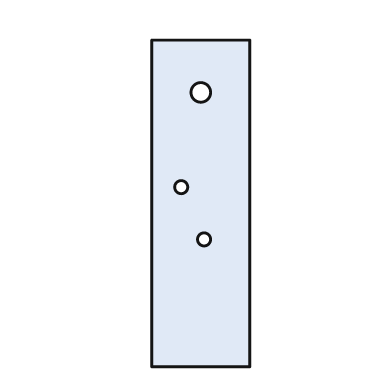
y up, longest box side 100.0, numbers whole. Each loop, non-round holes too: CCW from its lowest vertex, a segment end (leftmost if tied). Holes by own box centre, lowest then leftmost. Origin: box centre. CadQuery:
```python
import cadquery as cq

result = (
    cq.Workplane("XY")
    .moveTo(-15.0, -50.0)
    .lineTo(15.0, -50.0)
    .lineTo(15.0, 50.0)
    .lineTo(-15.0, 50.0)
    .close()
    .moveTo(1.0, -11.0)
    .circle(2.0)
    .moveTo(-6.0, 5.0)
    .circle(2.0)
    .moveTo(0.0, 34.0)
    .circle(3.0)
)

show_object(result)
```